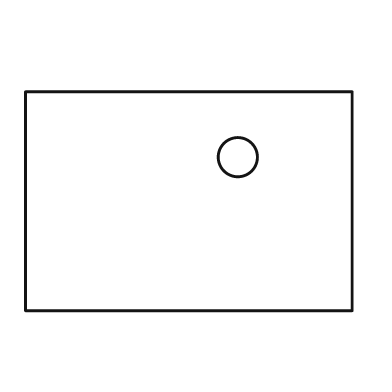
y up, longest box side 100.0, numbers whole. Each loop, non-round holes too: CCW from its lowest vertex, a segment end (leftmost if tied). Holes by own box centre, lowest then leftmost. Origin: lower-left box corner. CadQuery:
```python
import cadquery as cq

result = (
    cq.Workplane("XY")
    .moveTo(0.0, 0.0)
    .lineTo(100.0, 0.0)
    .lineTo(100.0, 67.0)
    .lineTo(0.0, 67.0)
    .close()
    .moveTo(65.0, 47.0)
    .circle(6.0)
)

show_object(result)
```